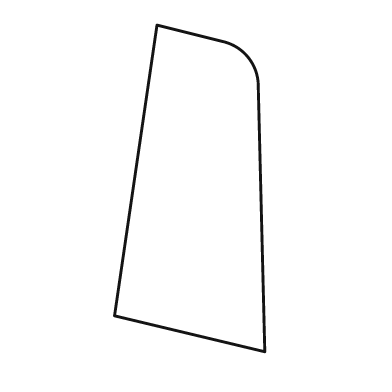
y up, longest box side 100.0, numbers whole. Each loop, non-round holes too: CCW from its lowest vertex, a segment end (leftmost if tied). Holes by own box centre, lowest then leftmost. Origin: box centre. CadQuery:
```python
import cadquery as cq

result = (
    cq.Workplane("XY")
    .moveTo(23.0, -50.0)
    .lineTo(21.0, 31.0)
    .threePointArc((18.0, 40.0), (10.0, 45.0))
    .lineTo(-10.0, 50.0)
    .lineTo(-23.0, -39.0)
    .close()
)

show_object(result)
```